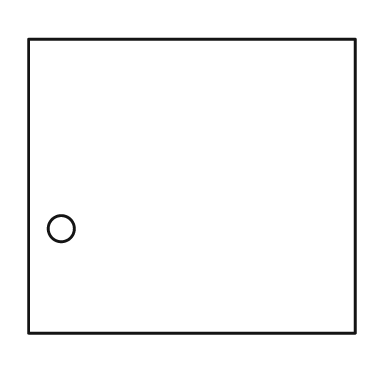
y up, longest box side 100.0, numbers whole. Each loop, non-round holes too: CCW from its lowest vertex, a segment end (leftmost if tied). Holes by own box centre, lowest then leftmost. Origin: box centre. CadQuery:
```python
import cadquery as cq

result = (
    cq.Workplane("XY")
    .moveTo(-50.0, -45.0)
    .lineTo(50.0, -45.0)
    .lineTo(50.0, 45.0)
    .lineTo(-50.0, 45.0)
    .close()
    .moveTo(-40.0, -13.0)
    .circle(4.0)
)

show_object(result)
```